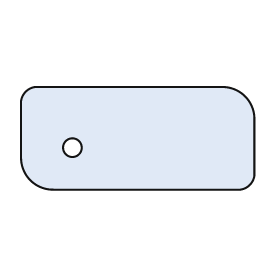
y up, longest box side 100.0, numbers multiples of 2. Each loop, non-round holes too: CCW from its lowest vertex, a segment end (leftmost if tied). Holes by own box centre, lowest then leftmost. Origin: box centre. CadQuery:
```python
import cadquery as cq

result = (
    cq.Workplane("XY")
    .moveTo(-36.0, -22.0)
    .lineTo(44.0, -22.0)
    .threePointArc((48.0, -20.0), (50.0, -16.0))
    .lineTo(50.0, 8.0)
    .threePointArc((46.0, 18.0), (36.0, 22.0))
    .lineTo(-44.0, 22.0)
    .threePointArc((-48.0, 20.0), (-50.0, 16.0))
    .lineTo(-50.0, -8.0)
    .threePointArc((-46.0, -18.0), (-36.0, -22.0))
    .close()
    .moveTo(-28.0, -4.0)
    .circle(4.0)
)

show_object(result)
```